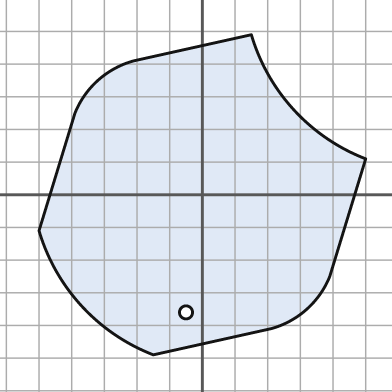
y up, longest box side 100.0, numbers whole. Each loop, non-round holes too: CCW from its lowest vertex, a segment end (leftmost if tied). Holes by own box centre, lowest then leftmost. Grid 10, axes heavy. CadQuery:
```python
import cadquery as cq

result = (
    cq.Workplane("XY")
    .moveTo(-15.0, -49.0)
    .lineTo(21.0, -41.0)
    .threePointArc((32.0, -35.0), (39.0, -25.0))
    .lineTo(50.0, 11.0)
    .threePointArc((28.0, 26.0), (15.0, 49.0))
    .lineTo(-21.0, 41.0)
    .threePointArc((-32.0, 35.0), (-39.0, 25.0))
    .lineTo(-50.0, -11.0)
    .threePointArc((-37.0, -34.0), (-15.0, -49.0))
    .close()
    .moveTo(-5.0, -36.0)
    .circle(2.0)
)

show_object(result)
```